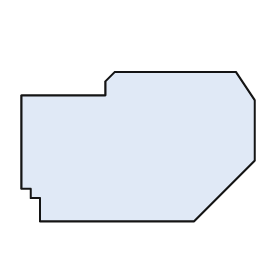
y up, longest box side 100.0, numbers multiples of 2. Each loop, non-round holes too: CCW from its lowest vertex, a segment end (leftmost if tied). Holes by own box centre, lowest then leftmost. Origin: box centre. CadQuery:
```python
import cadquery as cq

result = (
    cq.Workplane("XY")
    .moveTo(-42.0, -32.0)
    .lineTo(24.0, -32.0)
    .lineTo(50.0, -6.0)
    .lineTo(50.0, 20.0)
    .lineTo(42.0, 32.0)
    .lineTo(-10.0, 32.0)
    .lineTo(-14.0, 28.0)
    .lineTo(-14.0, 22.0)
    .lineTo(-50.0, 22.0)
    .lineTo(-50.0, -18.0)
    .lineTo(-46.0, -18.0)
    .lineTo(-46.0, -22.0)
    .lineTo(-42.0, -22.0)
    .close()
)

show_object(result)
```